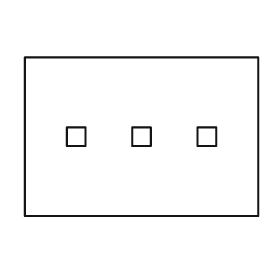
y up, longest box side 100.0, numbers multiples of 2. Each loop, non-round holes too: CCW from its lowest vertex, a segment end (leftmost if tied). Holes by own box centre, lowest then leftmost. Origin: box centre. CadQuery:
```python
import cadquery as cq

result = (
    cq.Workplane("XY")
    .moveTo(-50.0, -34.0)
    .lineTo(50.0, -34.0)
    .lineTo(50.0, 34.0)
    .lineTo(-50.0, 34.0)
    .close()
    .moveTo(-32.0, -4.0)
    .lineTo(-24.0, -4.0)
    .lineTo(-24.0, 4.0)
    .lineTo(-32.0, 4.0)
    .close()
    .moveTo(-4.0, -4.0)
    .lineTo(4.0, -4.0)
    .lineTo(4.0, 4.0)
    .lineTo(-4.0, 4.0)
    .close()
    .moveTo(24.0, -4.0)
    .lineTo(32.0, -4.0)
    .lineTo(32.0, 4.0)
    .lineTo(24.0, 4.0)
    .close()
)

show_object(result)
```